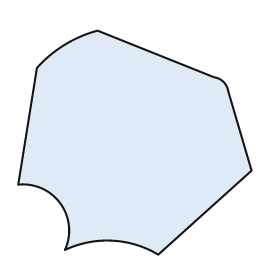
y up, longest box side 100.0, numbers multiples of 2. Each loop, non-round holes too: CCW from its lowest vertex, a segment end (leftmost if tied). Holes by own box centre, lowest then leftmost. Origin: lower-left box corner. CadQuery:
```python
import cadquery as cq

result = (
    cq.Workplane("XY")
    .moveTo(60.0, 0.0)
    .lineTo(100.0, 36.0)
    .lineTo(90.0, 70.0)
    .threePointArc((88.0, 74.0), (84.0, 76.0))
    .lineTo(34.0, 96.0)
    .threePointArc((20.0, 90.0), (8.0, 80.0))
    .lineTo(0.0, 30.0)
    .threePointArc((18.0, 22.0), (20.0, 2.0))
    .threePointArc((40.0, 6.0), (60.0, 0.0))
    .close()
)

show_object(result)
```